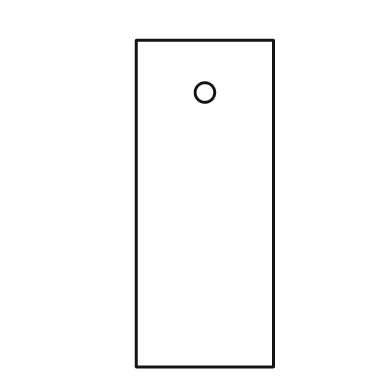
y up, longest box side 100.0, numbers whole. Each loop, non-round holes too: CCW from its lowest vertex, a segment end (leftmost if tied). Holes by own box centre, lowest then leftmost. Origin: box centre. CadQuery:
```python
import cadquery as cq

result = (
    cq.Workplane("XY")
    .moveTo(-21.0, -50.0)
    .lineTo(21.0, -50.0)
    .lineTo(21.0, 50.0)
    .lineTo(-21.0, 50.0)
    .close()
    .moveTo(0.0, 34.0)
    .circle(3.0)
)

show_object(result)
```